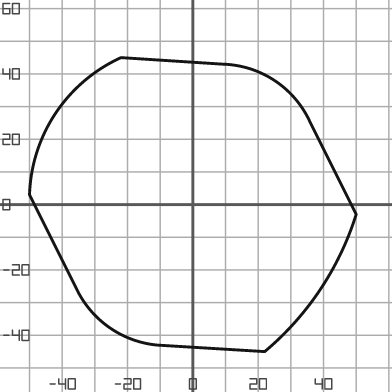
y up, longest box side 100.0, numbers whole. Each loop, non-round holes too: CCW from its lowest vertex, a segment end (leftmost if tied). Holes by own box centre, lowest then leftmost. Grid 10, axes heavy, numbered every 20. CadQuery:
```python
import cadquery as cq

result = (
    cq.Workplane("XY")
    .moveTo(22.0, -45.0)
    .threePointArc((39.0, -26.0), (50.0, -3.0))
    .lineTo(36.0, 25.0)
    .threePointArc((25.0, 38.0), (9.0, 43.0))
    .lineTo(-22.0, 45.0)
    .threePointArc((-42.0, 28.0), (-50.0, 3.0))
    .lineTo(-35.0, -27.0)
    .threePointArc((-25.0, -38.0), (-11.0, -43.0))
    .close()
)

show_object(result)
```